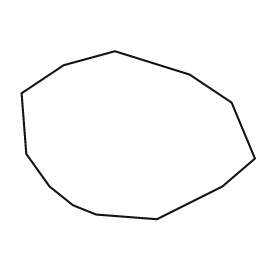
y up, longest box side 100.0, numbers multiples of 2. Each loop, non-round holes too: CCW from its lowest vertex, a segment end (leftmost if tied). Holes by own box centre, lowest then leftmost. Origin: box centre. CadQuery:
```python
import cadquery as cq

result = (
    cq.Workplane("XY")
    .moveTo(8.0, -36.0)
    .lineTo(36.0, -22.0)
    .lineTo(50.0, -10.0)
    .lineTo(40.0, 14.0)
    .lineTo(22.0, 26.0)
    .lineTo(-10.0, 36.0)
    .lineTo(-32.0, 30.0)
    .lineTo(-50.0, 18.0)
    .lineTo(-48.0, -8.0)
    .lineTo(-38.0, -22.0)
    .lineTo(-28.0, -30.0)
    .lineTo(-18.0, -34.0)
    .close()
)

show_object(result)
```